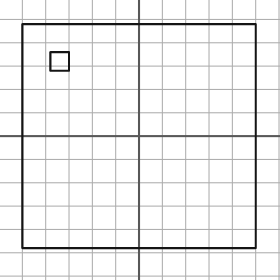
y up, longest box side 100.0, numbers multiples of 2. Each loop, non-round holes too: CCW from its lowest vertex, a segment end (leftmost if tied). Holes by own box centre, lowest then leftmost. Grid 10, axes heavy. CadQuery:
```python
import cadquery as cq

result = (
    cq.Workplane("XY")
    .moveTo(-50.0, -48.0)
    .lineTo(50.0, -48.0)
    .lineTo(50.0, 48.0)
    .lineTo(-50.0, 48.0)
    .close()
    .moveTo(-38.0, 28.0)
    .lineTo(-30.0, 28.0)
    .lineTo(-30.0, 36.0)
    .lineTo(-38.0, 36.0)
    .close()
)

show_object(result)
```